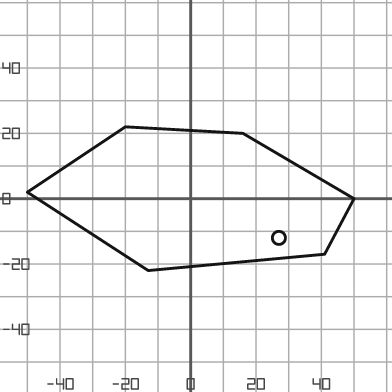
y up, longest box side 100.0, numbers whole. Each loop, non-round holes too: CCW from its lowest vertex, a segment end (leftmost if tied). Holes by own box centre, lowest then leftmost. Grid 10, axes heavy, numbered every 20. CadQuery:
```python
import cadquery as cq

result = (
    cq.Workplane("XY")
    .moveTo(-13.0, -22.0)
    .lineTo(41.0, -17.0)
    .lineTo(50.0, 0.0)
    .lineTo(16.0, 20.0)
    .lineTo(-20.0, 22.0)
    .lineTo(-50.0, 2.0)
    .close()
    .moveTo(27.0, -12.0)
    .circle(2.0)
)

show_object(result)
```